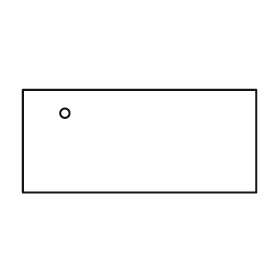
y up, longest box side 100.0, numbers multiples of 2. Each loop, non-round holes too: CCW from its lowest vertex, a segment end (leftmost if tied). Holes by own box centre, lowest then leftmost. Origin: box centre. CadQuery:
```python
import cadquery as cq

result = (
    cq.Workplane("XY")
    .moveTo(-50.0, -22.0)
    .lineTo(50.0, -22.0)
    .lineTo(50.0, 22.0)
    .lineTo(-50.0, 22.0)
    .close()
    .moveTo(-32.0, 12.0)
    .circle(2.0)
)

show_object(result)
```